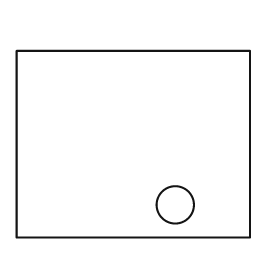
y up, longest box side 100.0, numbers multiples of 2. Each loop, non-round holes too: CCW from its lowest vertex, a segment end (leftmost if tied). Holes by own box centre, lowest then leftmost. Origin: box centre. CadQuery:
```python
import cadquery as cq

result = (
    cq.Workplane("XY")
    .moveTo(-50.0, -40.0)
    .lineTo(50.0, -40.0)
    .lineTo(50.0, 40.0)
    .lineTo(-50.0, 40.0)
    .close()
    .moveTo(18.0, -26.0)
    .circle(8.0)
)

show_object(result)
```